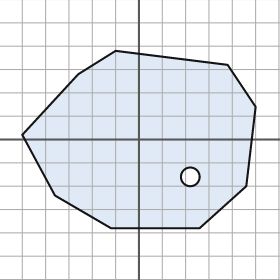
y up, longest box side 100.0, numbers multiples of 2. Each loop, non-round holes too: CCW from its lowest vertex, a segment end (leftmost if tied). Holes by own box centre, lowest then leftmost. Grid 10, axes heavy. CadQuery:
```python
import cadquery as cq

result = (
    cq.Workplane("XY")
    .moveTo(-12.0, -38.0)
    .lineTo(26.0, -38.0)
    .lineTo(46.0, -20.0)
    .lineTo(50.0, 14.0)
    .lineTo(38.0, 32.0)
    .lineTo(-10.0, 38.0)
    .lineTo(-26.0, 28.0)
    .lineTo(-50.0, 2.0)
    .lineTo(-36.0, -24.0)
    .close()
    .moveTo(22.0, -16.0)
    .circle(4.0)
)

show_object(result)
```